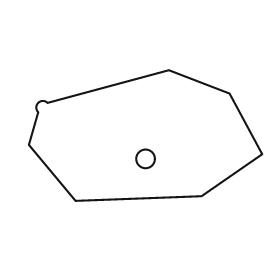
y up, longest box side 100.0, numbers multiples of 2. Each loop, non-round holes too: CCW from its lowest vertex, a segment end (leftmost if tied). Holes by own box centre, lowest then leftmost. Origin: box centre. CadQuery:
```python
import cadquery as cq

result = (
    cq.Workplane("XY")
    .moveTo(-30.0, -28.0)
    .lineTo(24.0, -26.0)
    .lineTo(50.0, -8.0)
    .lineTo(36.0, 18.0)
    .lineTo(10.0, 28.0)
    .lineTo(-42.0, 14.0)
    .threePointArc((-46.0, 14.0), (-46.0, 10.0))
    .lineTo(-50.0, -4.0)
    .close()
    .moveTo(0.0, -10.0)
    .circle(4.0)
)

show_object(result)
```